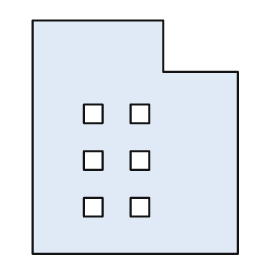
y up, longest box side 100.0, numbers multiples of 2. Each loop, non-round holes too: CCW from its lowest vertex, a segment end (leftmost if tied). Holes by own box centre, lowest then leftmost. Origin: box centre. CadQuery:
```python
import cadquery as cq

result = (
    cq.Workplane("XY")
    .moveTo(-44.0, -50.0)
    .lineTo(44.0, -50.0)
    .lineTo(44.0, 28.0)
    .lineTo(12.0, 28.0)
    .lineTo(12.0, 50.0)
    .lineTo(-44.0, 50.0)
    .close()
    .moveTo(-22.0, -34.0)
    .lineTo(-14.0, -34.0)
    .lineTo(-14.0, -26.0)
    .lineTo(-22.0, -26.0)
    .close()
    .moveTo(-2.0, -34.0)
    .lineTo(6.0, -34.0)
    .lineTo(6.0, -26.0)
    .lineTo(-2.0, -26.0)
    .close()
    .moveTo(-22.0, -14.0)
    .lineTo(-14.0, -14.0)
    .lineTo(-14.0, -6.0)
    .lineTo(-22.0, -6.0)
    .close()
    .moveTo(-2.0, -14.0)
    .lineTo(6.0, -14.0)
    .lineTo(6.0, -6.0)
    .lineTo(-2.0, -6.0)
    .close()
    .moveTo(-22.0, 6.0)
    .lineTo(-14.0, 6.0)
    .lineTo(-14.0, 14.0)
    .lineTo(-22.0, 14.0)
    .close()
    .moveTo(-2.0, 6.0)
    .lineTo(6.0, 6.0)
    .lineTo(6.0, 14.0)
    .lineTo(-2.0, 14.0)
    .close()
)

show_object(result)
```